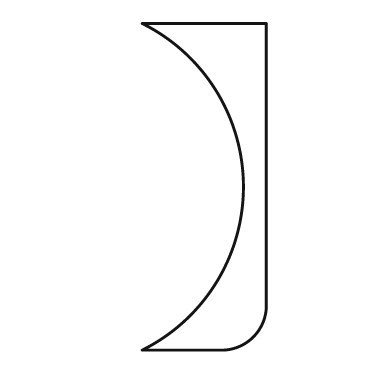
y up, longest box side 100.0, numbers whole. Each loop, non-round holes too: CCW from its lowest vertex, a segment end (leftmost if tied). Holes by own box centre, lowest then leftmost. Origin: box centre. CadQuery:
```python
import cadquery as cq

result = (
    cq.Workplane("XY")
    .moveTo(-19.0, -50.0)
    .lineTo(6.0, -50.0)
    .threePointArc((15.0, -46.0), (19.0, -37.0))
    .lineTo(19.0, 50.0)
    .lineTo(-19.0, 50.0)
    .threePointArc((12.0, 0.0), (-19.0, -50.0))
    .close()
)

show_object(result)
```